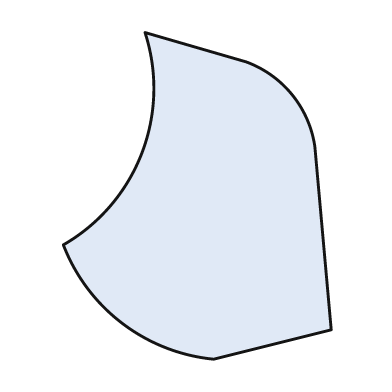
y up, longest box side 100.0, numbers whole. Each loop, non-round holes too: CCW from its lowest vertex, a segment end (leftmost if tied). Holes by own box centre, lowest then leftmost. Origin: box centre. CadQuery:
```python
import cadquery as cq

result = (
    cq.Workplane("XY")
    .moveTo(5.0, -50.0)
    .lineTo(41.0, -41.0)
    .lineTo(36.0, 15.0)
    .threePointArc((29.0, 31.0), (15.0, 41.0))
    .lineTo(-16.0, 50.0)
    .threePointArc((-17.0, 13.0), (-41.0, -15.0))
    .threePointArc((-23.0, -39.0), (5.0, -50.0))
    .close()
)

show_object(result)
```